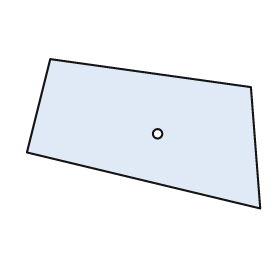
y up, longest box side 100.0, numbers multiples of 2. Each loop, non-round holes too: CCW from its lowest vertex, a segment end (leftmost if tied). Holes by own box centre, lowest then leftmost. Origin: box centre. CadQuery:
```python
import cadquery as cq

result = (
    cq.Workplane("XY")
    .moveTo(50.0, -32.0)
    .lineTo(46.0, 20.0)
    .lineTo(-40.0, 32.0)
    .lineTo(-50.0, -8.0)
    .close()
    .moveTo(6.0, 0.0)
    .circle(2.0)
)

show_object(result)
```